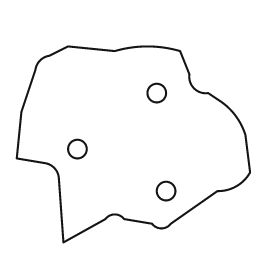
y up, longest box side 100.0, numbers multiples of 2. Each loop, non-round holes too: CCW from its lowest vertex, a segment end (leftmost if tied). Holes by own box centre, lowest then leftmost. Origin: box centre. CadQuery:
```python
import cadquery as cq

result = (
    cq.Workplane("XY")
    .moveTo(-30.0, -42.0)
    .lineTo(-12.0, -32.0)
    .threePointArc((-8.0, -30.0), (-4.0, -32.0))
    .lineTo(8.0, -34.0)
    .threePointArc((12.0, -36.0), (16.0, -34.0))
    .lineTo(36.0, -20.0)
    .threePointArc((44.0, -18.0), (50.0, -12.0))
    .lineTo(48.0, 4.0)
    .threePointArc((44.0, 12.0), (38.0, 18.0))
    .lineTo(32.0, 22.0)
    .threePointArc((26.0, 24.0), (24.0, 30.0))
    .lineTo(20.0, 40.0)
    .threePointArc((6.0, 42.0), (-8.0, 40.0))
    .lineTo(-28.0, 42.0)
    .lineTo(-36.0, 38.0)
    .threePointArc((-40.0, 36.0), (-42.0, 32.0))
    .lineTo(-48.0, 14.0)
    .lineTo(-50.0, -6.0)
    .lineTo(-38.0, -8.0)
    .threePointArc((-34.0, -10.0), (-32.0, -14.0))
    .close()
    .moveTo(14.0, -20.0)
    .circle(4.0)
    .moveTo(-24.0, -2.0)
    .circle(4.0)
    .moveTo(10.0, 22.0)
    .circle(4.0)
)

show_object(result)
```